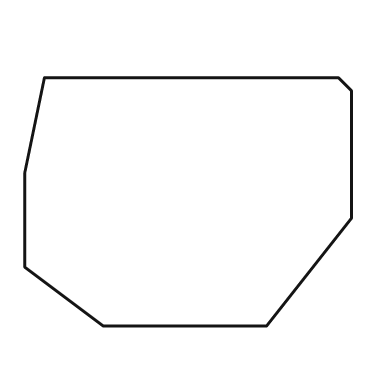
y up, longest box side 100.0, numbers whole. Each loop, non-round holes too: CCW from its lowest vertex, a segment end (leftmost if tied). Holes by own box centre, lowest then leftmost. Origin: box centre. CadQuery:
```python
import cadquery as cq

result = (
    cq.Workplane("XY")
    .moveTo(-26.0, -38.0)
    .lineTo(24.0, -38.0)
    .lineTo(50.0, -5.0)
    .lineTo(50.0, 34.0)
    .lineTo(46.0, 38.0)
    .lineTo(-44.0, 38.0)
    .lineTo(-50.0, 9.0)
    .lineTo(-50.0, -20.0)
    .close()
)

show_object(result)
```